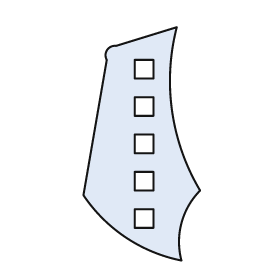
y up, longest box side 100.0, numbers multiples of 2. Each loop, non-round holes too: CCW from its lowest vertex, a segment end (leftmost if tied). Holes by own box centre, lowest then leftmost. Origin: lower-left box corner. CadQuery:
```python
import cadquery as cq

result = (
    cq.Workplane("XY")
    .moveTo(42.0, 0.0)
    .threePointArc((42.0, 16.0), (50.0, 30.0))
    .threePointArc((38.0, 64.0), (40.0, 100.0))
    .lineTo(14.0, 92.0)
    .threePointArc((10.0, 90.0), (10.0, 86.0))
    .lineTo(0.0, 28.0)
    .threePointArc((18.0, 10.0), (42.0, 0.0))
    .close()
    .moveTo(22.0, 14.0)
    .lineTo(30.0, 14.0)
    .lineTo(30.0, 22.0)
    .lineTo(22.0, 22.0)
    .close()
    .moveTo(22.0, 30.0)
    .lineTo(30.0, 30.0)
    .lineTo(30.0, 38.0)
    .lineTo(22.0, 38.0)
    .close()
    .moveTo(22.0, 46.0)
    .lineTo(30.0, 46.0)
    .lineTo(30.0, 54.0)
    .lineTo(22.0, 54.0)
    .close()
    .moveTo(22.0, 62.0)
    .lineTo(30.0, 62.0)
    .lineTo(30.0, 70.0)
    .lineTo(22.0, 70.0)
    .close()
    .moveTo(22.0, 78.0)
    .lineTo(30.0, 78.0)
    .lineTo(30.0, 86.0)
    .lineTo(22.0, 86.0)
    .close()
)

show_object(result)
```